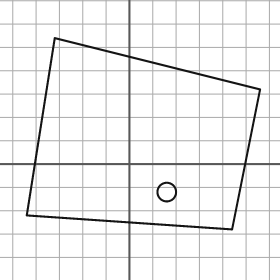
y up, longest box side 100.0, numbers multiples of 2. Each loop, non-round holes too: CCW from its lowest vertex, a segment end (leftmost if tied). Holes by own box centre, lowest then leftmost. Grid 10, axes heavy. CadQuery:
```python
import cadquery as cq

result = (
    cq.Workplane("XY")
    .moveTo(44.0, -28.0)
    .lineTo(56.0, 32.0)
    .lineTo(-32.0, 54.0)
    .lineTo(-44.0, -22.0)
    .close()
    .moveTo(16.0, -12.0)
    .circle(4.0)
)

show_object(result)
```